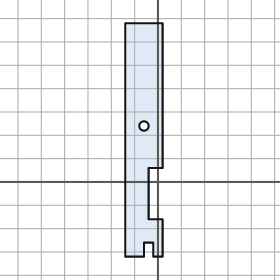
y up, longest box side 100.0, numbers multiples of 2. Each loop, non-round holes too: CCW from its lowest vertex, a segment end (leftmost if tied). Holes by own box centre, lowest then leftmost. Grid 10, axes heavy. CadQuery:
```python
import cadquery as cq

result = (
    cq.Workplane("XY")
    .moveTo(-14.0, -32.0)
    .lineTo(-6.0, -32.0)
    .lineTo(-6.0, -26.0)
    .lineTo(-2.0, -26.0)
    .lineTo(-2.0, -32.0)
    .lineTo(2.0, -32.0)
    .lineTo(2.0, -16.0)
    .lineTo(-4.0, -16.0)
    .lineTo(-4.0, 6.0)
    .lineTo(2.0, 6.0)
    .lineTo(2.0, 68.0)
    .lineTo(-14.0, 68.0)
    .close()
    .moveTo(-6.0, 24.0)
    .circle(2.0)
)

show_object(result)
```